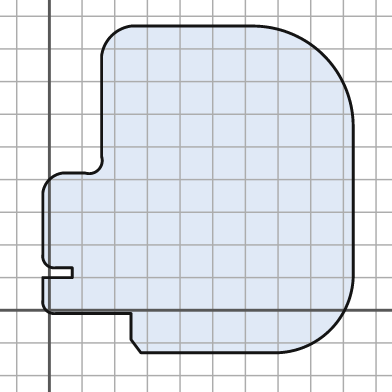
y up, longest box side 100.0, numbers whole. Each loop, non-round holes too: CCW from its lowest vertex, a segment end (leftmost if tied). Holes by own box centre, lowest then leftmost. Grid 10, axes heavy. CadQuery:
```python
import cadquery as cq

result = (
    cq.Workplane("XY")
    .moveTo(28.0, -13.0)
    .lineTo(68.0, -13.0)
    .threePointArc((86.0, -6.0), (93.0, 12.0))
    .lineTo(93.0, 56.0)
    .threePointArc((84.0, 78.0), (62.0, 87.0))
    .lineTo(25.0, 87.0)
    .threePointArc((19.0, 84.0), (16.0, 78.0))
    .lineTo(16.0, 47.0)
    .threePointArc((15.0, 43.0), (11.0, 42.0))
    .lineTo(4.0, 42.0)
    .threePointArc((0.0, 40.0), (-2.0, 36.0))
    .lineTo(-2.0, 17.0)
    .threePointArc((-1.0, 14.0), (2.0, 13.0))
    .lineTo(7.0, 13.0)
    .lineTo(7.0, 10.0)
    .lineTo(-2.0, 10.0)
    .lineTo(-2.0, 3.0)
    .threePointArc((-1.0, 0.0), (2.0, -1.0))
    .lineTo(25.0, -1.0)
    .lineTo(25.0, -9.0)
    .close()
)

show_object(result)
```